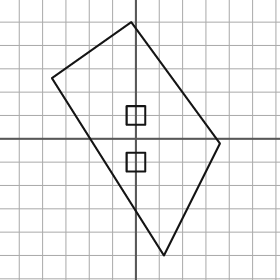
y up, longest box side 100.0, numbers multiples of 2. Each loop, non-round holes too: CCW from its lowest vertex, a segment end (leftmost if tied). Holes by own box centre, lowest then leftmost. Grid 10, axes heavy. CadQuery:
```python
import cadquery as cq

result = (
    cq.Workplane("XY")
    .moveTo(12.0, -50.0)
    .lineTo(36.0, -2.0)
    .lineTo(-2.0, 50.0)
    .lineTo(-36.0, 26.0)
    .close()
    .moveTo(-4.0, -14.0)
    .lineTo(4.0, -14.0)
    .lineTo(4.0, -6.0)
    .lineTo(-4.0, -6.0)
    .close()
    .moveTo(-4.0, 6.0)
    .lineTo(4.0, 6.0)
    .lineTo(4.0, 14.0)
    .lineTo(-4.0, 14.0)
    .close()
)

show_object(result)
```